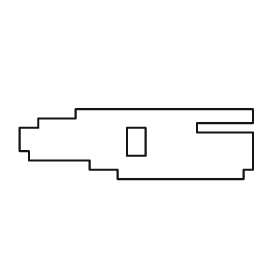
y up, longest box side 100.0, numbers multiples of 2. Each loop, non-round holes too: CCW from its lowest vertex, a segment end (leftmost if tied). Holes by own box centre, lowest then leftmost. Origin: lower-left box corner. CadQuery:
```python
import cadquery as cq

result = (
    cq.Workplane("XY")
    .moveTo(42.0, 0.0)
    .lineTo(96.0, 0.0)
    .lineTo(96.0, 4.0)
    .lineTo(100.0, 4.0)
    .lineTo(100.0, 20.0)
    .lineTo(76.0, 20.0)
    .lineTo(76.0, 24.0)
    .lineTo(100.0, 24.0)
    .lineTo(100.0, 30.0)
    .lineTo(24.0, 30.0)
    .lineTo(24.0, 26.0)
    .lineTo(8.0, 26.0)
    .lineTo(8.0, 22.0)
    .lineTo(0.0, 22.0)
    .lineTo(0.0, 12.0)
    .lineTo(4.0, 12.0)
    .lineTo(4.0, 8.0)
    .lineTo(30.0, 8.0)
    .lineTo(30.0, 4.0)
    .lineTo(42.0, 4.0)
    .close()
    .moveTo(46.0, 10.0)
    .lineTo(54.0, 10.0)
    .lineTo(54.0, 22.0)
    .lineTo(46.0, 22.0)
    .close()
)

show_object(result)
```